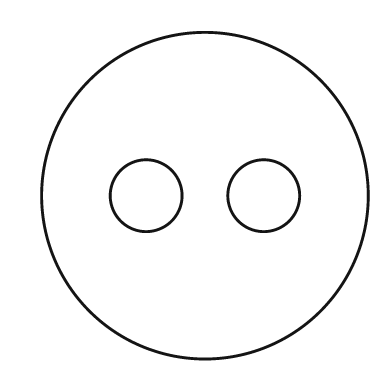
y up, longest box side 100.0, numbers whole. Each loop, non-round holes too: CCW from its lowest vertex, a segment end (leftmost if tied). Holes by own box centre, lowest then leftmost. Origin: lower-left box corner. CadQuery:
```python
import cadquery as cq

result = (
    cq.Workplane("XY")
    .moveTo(50.0, 50.0)
    .circle(50.0)
    .moveTo(32.0, 50.0)
    .circle(11.0)
    .moveTo(68.0, 50.0)
    .circle(11.0)
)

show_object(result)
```